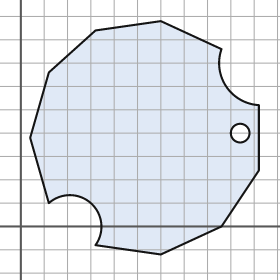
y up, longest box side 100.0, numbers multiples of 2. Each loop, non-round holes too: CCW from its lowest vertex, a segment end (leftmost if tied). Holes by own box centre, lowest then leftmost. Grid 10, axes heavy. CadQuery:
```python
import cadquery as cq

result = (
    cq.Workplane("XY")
    .moveTo(60.0, -12.0)
    .lineTo(86.0, 0.0)
    .lineTo(102.0, 24.0)
    .lineTo(102.0, 52.0)
    .threePointArc((88.0, 60.0), (86.0, 76.0))
    .lineTo(60.0, 88.0)
    .lineTo(32.0, 84.0)
    .lineTo(12.0, 66.0)
    .lineTo(4.0, 38.0)
    .lineTo(12.0, 10.0)
    .threePointArc((30.0, 10.0), (32.0, -8.0))
    .close()
    .moveTo(94.0, 40.0)
    .circle(4.0)
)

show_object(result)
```